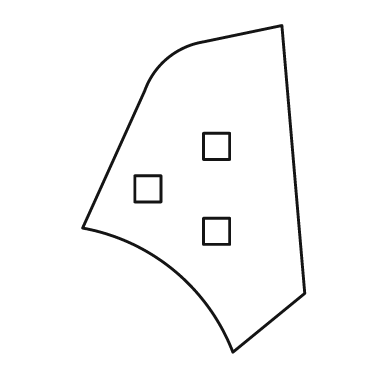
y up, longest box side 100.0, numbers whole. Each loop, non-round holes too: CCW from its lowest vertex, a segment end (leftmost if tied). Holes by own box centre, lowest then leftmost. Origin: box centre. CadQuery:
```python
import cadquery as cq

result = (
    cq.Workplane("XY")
    .moveTo(12.0, -50.0)
    .lineTo(34.0, -32.0)
    .lineTo(27.0, 50.0)
    .lineTo(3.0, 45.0)
    .threePointArc((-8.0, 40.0), (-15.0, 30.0))
    .lineTo(-34.0, -12.0)
    .threePointArc((-6.0, -25.0), (12.0, -50.0))
    .close()
    .moveTo(3.0, -17.0)
    .lineTo(11.0, -17.0)
    .lineTo(11.0, -9.0)
    .lineTo(3.0, -9.0)
    .close()
    .moveTo(-18.0, -4.0)
    .lineTo(-10.0, -4.0)
    .lineTo(-10.0, 4.0)
    .lineTo(-18.0, 4.0)
    .close()
    .moveTo(3.0, 9.0)
    .lineTo(11.0, 9.0)
    .lineTo(11.0, 17.0)
    .lineTo(3.0, 17.0)
    .close()
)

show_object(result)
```